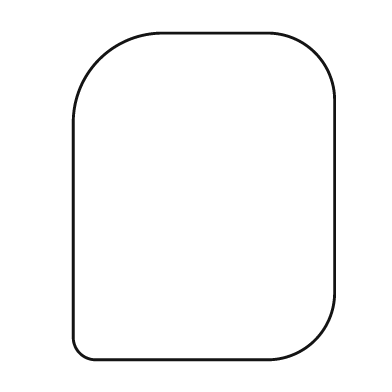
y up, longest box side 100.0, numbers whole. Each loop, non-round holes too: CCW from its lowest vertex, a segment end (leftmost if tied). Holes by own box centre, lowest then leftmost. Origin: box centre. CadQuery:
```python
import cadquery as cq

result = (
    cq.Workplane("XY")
    .moveTo(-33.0, -50.0)
    .lineTo(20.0, -50.0)
    .threePointArc((34.0, -44.0), (40.0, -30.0))
    .lineTo(40.0, 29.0)
    .threePointArc((34.0, 44.0), (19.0, 50.0))
    .lineTo(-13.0, 50.0)
    .threePointArc((-32.0, 42.0), (-40.0, 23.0))
    .lineTo(-40.0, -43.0)
    .threePointArc((-38.0, -48.0), (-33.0, -50.0))
    .close()
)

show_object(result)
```